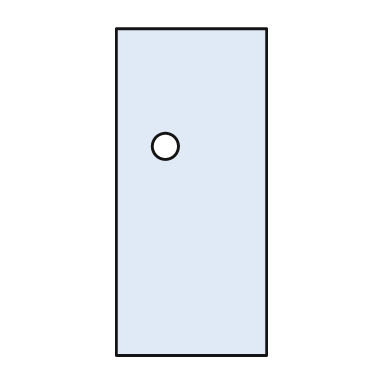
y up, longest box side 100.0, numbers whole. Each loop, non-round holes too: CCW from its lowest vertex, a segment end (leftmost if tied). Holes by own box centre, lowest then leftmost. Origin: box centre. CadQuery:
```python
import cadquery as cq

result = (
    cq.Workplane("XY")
    .moveTo(-23.0, -50.0)
    .lineTo(23.0, -50.0)
    .lineTo(23.0, 50.0)
    .lineTo(-23.0, 50.0)
    .close()
    .moveTo(-8.0, 14.0)
    .circle(4.0)
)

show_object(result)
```